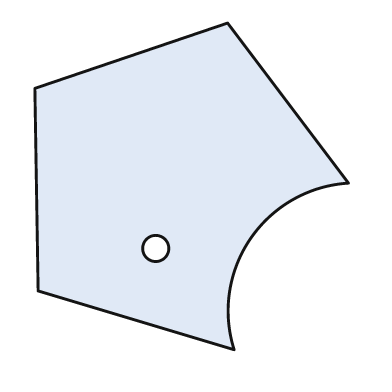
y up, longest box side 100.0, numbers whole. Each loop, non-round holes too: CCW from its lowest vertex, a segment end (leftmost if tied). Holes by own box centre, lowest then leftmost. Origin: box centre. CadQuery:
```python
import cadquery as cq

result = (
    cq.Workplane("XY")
    .moveTo(13.0, -50.0)
    .threePointArc((18.0, -16.0), (48.0, 1.0))
    .lineTo(11.0, 50.0)
    .lineTo(-48.0, 30.0)
    .lineTo(-47.0, -32.0)
    .close()
    .moveTo(-11.0, -19.0)
    .circle(4.0)
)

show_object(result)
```